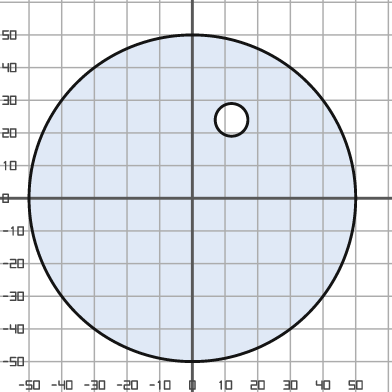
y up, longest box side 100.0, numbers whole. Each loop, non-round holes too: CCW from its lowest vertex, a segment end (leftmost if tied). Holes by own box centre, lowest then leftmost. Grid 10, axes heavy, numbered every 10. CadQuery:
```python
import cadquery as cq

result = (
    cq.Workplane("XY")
    .moveTo(0.0, 0.0)
    .circle(50.0)
    .moveTo(12.0, 24.0)
    .circle(5.0)
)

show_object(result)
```